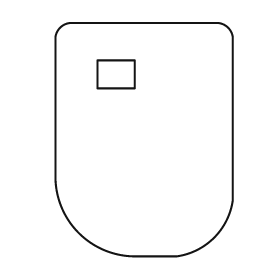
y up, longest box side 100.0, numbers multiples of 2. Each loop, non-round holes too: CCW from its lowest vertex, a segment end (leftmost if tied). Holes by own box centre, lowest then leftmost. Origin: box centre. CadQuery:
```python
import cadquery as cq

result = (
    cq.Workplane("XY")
    .moveTo(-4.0, -50.0)
    .lineTo(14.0, -50.0)
    .threePointArc((30.0, -42.0), (38.0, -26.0))
    .lineTo(38.0, 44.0)
    .threePointArc((36.0, 48.0), (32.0, 50.0))
    .lineTo(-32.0, 50.0)
    .threePointArc((-36.0, 48.0), (-38.0, 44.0))
    .lineTo(-38.0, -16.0)
    .threePointArc((-28.0, -40.0), (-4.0, -50.0))
    .close()
    .moveTo(-20.0, 22.0)
    .lineTo(-4.0, 22.0)
    .lineTo(-4.0, 34.0)
    .lineTo(-20.0, 34.0)
    .close()
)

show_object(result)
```